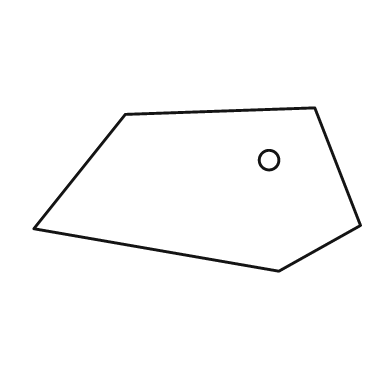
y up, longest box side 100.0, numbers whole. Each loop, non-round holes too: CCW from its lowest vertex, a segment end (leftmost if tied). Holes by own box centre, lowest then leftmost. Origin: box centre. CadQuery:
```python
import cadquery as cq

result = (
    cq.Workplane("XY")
    .moveTo(25.0, -25.0)
    .lineTo(50.0, -11.0)
    .lineTo(36.0, 25.0)
    .lineTo(-22.0, 23.0)
    .lineTo(-50.0, -12.0)
    .close()
    .moveTo(22.0, 9.0)
    .circle(3.0)
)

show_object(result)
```